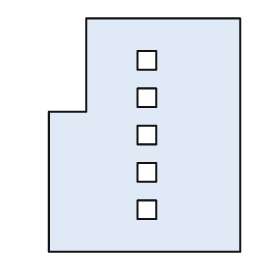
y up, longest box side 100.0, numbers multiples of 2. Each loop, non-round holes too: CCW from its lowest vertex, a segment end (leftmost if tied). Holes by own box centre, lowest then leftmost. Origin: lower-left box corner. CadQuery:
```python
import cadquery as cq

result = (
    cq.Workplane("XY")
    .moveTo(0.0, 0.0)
    .lineTo(82.0, 0.0)
    .lineTo(82.0, 100.0)
    .lineTo(16.0, 100.0)
    .lineTo(16.0, 60.0)
    .lineTo(0.0, 60.0)
    .close()
    .moveTo(38.0, 14.0)
    .lineTo(46.0, 14.0)
    .lineTo(46.0, 22.0)
    .lineTo(38.0, 22.0)
    .close()
    .moveTo(38.0, 30.0)
    .lineTo(46.0, 30.0)
    .lineTo(46.0, 38.0)
    .lineTo(38.0, 38.0)
    .close()
    .moveTo(38.0, 46.0)
    .lineTo(46.0, 46.0)
    .lineTo(46.0, 54.0)
    .lineTo(38.0, 54.0)
    .close()
    .moveTo(38.0, 62.0)
    .lineTo(46.0, 62.0)
    .lineTo(46.0, 70.0)
    .lineTo(38.0, 70.0)
    .close()
    .moveTo(38.0, 78.0)
    .lineTo(46.0, 78.0)
    .lineTo(46.0, 86.0)
    .lineTo(38.0, 86.0)
    .close()
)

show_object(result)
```